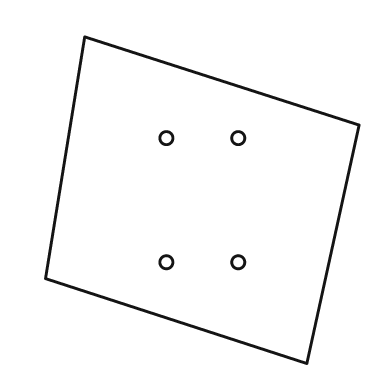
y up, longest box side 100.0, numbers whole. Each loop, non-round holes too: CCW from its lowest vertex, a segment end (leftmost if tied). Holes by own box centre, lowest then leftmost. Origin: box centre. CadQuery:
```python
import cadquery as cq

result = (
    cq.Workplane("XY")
    .moveTo(32.0, -50.0)
    .lineTo(48.0, 23.0)
    .lineTo(-36.0, 50.0)
    .lineTo(-48.0, -24.0)
    .close()
    .moveTo(-11.0, -19.0)
    .circle(2.0)
    .moveTo(11.0, -19.0)
    .circle(2.0)
    .moveTo(-11.0, 19.0)
    .circle(2.0)
    .moveTo(11.0, 19.0)
    .circle(2.0)
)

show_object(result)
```